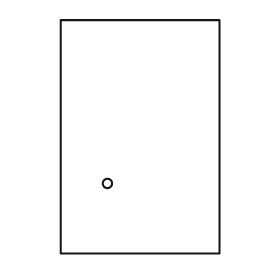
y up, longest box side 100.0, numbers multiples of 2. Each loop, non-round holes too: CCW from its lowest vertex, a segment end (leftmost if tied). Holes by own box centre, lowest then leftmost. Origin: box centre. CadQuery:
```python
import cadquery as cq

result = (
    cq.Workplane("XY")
    .moveTo(-34.0, -50.0)
    .lineTo(34.0, -50.0)
    .lineTo(34.0, 50.0)
    .lineTo(-34.0, 50.0)
    .close()
    .moveTo(-14.0, -20.0)
    .circle(2.0)
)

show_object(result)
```